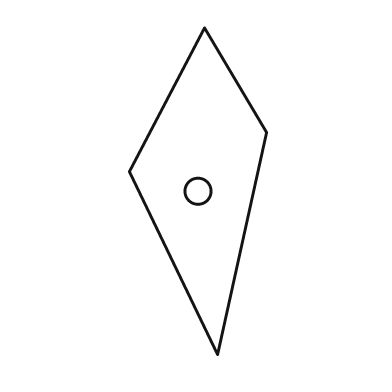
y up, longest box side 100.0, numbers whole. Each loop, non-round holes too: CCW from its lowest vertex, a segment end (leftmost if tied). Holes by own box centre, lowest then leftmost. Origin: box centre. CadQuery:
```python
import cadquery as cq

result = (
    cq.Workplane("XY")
    .moveTo(6.0, -50.0)
    .lineTo(21.0, 18.0)
    .lineTo(2.0, 50.0)
    .lineTo(-21.0, 6.0)
    .close()
    .moveTo(0.0, 0.0)
    .circle(4.0)
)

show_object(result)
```